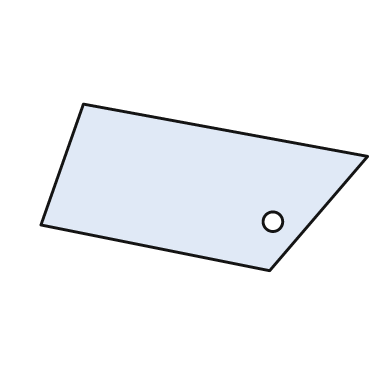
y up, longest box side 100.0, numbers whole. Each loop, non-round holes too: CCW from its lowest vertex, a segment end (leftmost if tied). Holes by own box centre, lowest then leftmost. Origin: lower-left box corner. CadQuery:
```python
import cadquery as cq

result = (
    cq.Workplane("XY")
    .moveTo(70.0, 0.0)
    .lineTo(100.0, 35.0)
    .lineTo(13.0, 51.0)
    .lineTo(0.0, 14.0)
    .close()
    .moveTo(71.0, 15.0)
    .circle(3.0)
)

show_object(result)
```